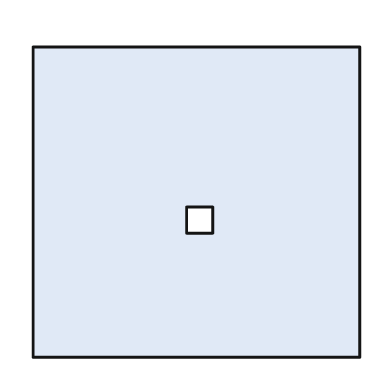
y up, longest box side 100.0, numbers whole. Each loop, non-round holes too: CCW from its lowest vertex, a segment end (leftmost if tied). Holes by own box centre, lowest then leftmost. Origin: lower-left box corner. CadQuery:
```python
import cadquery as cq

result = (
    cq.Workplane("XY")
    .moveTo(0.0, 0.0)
    .lineTo(100.0, 0.0)
    .lineTo(100.0, 95.0)
    .lineTo(0.0, 95.0)
    .close()
    .moveTo(47.0, 38.0)
    .lineTo(55.0, 38.0)
    .lineTo(55.0, 46.0)
    .lineTo(47.0, 46.0)
    .close()
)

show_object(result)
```